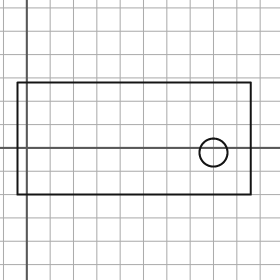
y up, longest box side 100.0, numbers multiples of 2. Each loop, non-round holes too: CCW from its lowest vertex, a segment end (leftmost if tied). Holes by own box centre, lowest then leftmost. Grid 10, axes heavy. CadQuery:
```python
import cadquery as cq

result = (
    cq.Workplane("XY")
    .moveTo(-4.0, -20.0)
    .lineTo(96.0, -20.0)
    .lineTo(96.0, 28.0)
    .lineTo(-4.0, 28.0)
    .close()
    .moveTo(80.0, -2.0)
    .circle(6.0)
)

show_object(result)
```